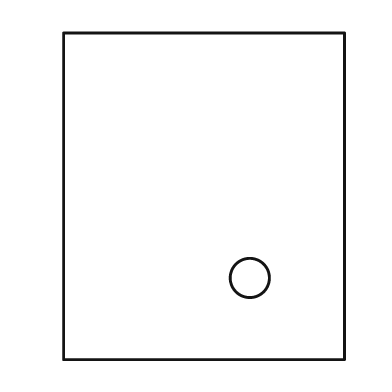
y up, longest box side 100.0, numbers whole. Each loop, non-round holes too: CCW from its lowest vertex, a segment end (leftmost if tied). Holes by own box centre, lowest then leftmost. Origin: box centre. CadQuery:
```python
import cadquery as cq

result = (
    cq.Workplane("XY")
    .moveTo(-43.0, -50.0)
    .lineTo(43.0, -50.0)
    .lineTo(43.0, 50.0)
    .lineTo(-43.0, 50.0)
    .close()
    .moveTo(14.0, -25.0)
    .circle(6.0)
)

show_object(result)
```